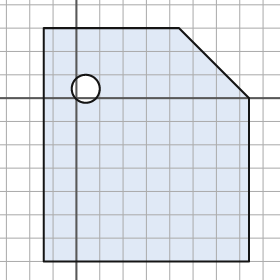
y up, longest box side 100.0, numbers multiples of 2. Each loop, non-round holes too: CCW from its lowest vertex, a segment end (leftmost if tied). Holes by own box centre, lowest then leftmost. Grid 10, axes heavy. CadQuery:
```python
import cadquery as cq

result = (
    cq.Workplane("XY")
    .moveTo(-14.0, -70.0)
    .lineTo(74.0, -70.0)
    .lineTo(74.0, 0.0)
    .lineTo(44.0, 30.0)
    .lineTo(-14.0, 30.0)
    .close()
    .moveTo(4.0, 4.0)
    .circle(6.0)
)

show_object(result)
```